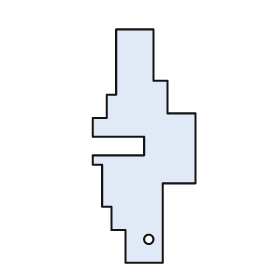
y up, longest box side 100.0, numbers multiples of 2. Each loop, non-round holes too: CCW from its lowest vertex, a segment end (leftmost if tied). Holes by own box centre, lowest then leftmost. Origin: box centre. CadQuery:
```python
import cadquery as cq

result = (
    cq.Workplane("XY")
    .moveTo(-8.0, -50.0)
    .lineTo(8.0, -50.0)
    .lineTo(8.0, -16.0)
    .lineTo(22.0, -16.0)
    .lineTo(22.0, 14.0)
    .lineTo(10.0, 14.0)
    .lineTo(10.0, 28.0)
    .lineTo(4.0, 28.0)
    .lineTo(4.0, 50.0)
    .lineTo(-12.0, 50.0)
    .lineTo(-12.0, 22.0)
    .lineTo(-16.0, 22.0)
    .lineTo(-16.0, 12.0)
    .lineTo(-22.0, 12.0)
    .lineTo(-22.0, 4.0)
    .lineTo(0.0, 4.0)
    .lineTo(0.0, -4.0)
    .lineTo(-22.0, -4.0)
    .lineTo(-22.0, -8.0)
    .lineTo(-18.0, -8.0)
    .lineTo(-18.0, -26.0)
    .lineTo(-14.0, -26.0)
    .lineTo(-14.0, -36.0)
    .lineTo(-8.0, -36.0)
    .close()
    .moveTo(2.0, -40.0)
    .circle(2.0)
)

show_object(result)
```